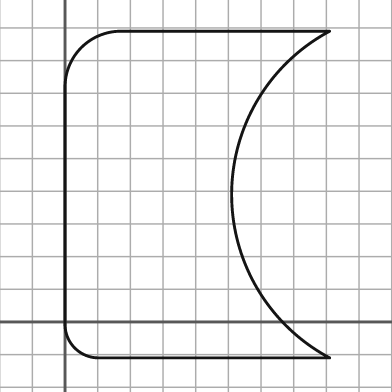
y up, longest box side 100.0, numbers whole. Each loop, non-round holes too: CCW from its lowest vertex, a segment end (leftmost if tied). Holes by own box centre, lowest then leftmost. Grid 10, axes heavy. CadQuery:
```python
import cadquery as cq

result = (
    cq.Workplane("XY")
    .moveTo(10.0, -11.0)
    .lineTo(81.0, -11.0)
    .threePointArc((51.0, 39.0), (81.0, 89.0))
    .lineTo(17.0, 89.0)
    .threePointArc((5.0, 84.0), (0.0, 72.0))
    .lineTo(0.0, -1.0)
    .threePointArc((3.0, -8.0), (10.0, -11.0))
    .close()
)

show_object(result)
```